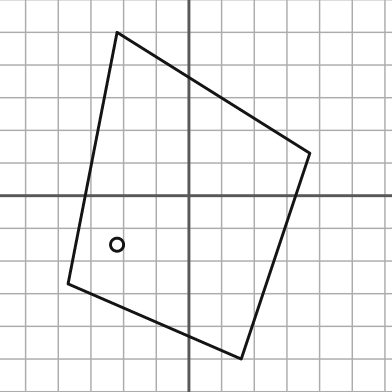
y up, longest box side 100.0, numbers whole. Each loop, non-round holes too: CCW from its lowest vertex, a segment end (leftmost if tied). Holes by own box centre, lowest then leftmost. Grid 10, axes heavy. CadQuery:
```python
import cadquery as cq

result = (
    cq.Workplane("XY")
    .moveTo(16.0, -50.0)
    .lineTo(37.0, 13.0)
    .lineTo(-22.0, 50.0)
    .lineTo(-37.0, -27.0)
    .close()
    .moveTo(-22.0, -15.0)
    .circle(2.0)
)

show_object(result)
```